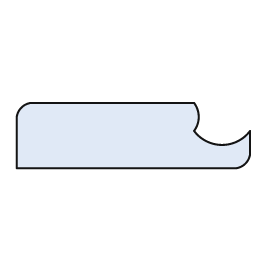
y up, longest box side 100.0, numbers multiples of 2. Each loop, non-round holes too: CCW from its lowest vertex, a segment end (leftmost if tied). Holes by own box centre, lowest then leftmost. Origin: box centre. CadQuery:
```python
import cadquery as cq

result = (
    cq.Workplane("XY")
    .moveTo(-50.0, -14.0)
    .lineTo(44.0, -14.0)
    .threePointArc((48.0, -12.0), (50.0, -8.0))
    .lineTo(50.0, 2.0)
    .threePointArc((38.0, -4.0), (26.0, 2.0))
    .threePointArc((28.0, 8.0), (26.0, 14.0))
    .lineTo(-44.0, 14.0)
    .threePointArc((-48.0, 12.0), (-50.0, 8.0))
    .close()
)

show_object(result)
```